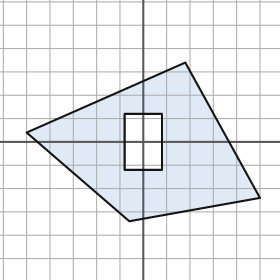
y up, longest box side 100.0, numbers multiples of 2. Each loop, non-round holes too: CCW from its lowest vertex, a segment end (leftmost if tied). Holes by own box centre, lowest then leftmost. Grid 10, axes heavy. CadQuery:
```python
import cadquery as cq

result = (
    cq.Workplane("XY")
    .moveTo(-6.0, -34.0)
    .lineTo(50.0, -24.0)
    .lineTo(18.0, 34.0)
    .lineTo(-50.0, 4.0)
    .close()
    .moveTo(-8.0, -12.0)
    .lineTo(8.0, -12.0)
    .lineTo(8.0, 12.0)
    .lineTo(-8.0, 12.0)
    .close()
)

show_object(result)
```